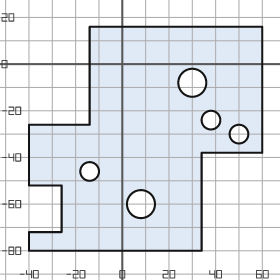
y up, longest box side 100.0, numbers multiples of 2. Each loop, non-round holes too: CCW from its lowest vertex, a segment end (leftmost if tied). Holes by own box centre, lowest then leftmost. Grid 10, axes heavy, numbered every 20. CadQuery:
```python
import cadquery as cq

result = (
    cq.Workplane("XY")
    .moveTo(-40.0, -80.0)
    .lineTo(34.0, -80.0)
    .lineTo(34.0, -38.0)
    .lineTo(60.0, -38.0)
    .lineTo(60.0, 16.0)
    .lineTo(-14.0, 16.0)
    .lineTo(-14.0, -26.0)
    .lineTo(-40.0, -26.0)
    .lineTo(-40.0, -52.0)
    .lineTo(-26.0, -52.0)
    .lineTo(-26.0, -72.0)
    .lineTo(-40.0, -72.0)
    .close()
    .moveTo(8.0, -60.0)
    .circle(6.0)
    .moveTo(-14.0, -46.0)
    .circle(4.0)
    .moveTo(50.0, -30.0)
    .circle(4.0)
    .moveTo(38.0, -24.0)
    .circle(4.0)
    .moveTo(30.0, -8.0)
    .circle(6.0)
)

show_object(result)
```